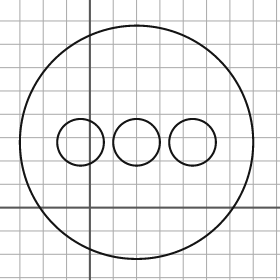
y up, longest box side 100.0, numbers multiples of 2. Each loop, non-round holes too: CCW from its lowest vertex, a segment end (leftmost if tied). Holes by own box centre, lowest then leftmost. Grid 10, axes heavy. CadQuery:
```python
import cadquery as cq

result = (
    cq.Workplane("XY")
    .moveTo(20.0, 28.0)
    .circle(50.0)
    .moveTo(-4.0, 28.0)
    .circle(10.0)
    .moveTo(20.0, 28.0)
    .circle(10.0)
    .moveTo(44.0, 28.0)
    .circle(10.0)
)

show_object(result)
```